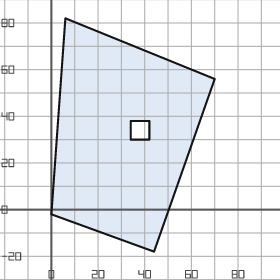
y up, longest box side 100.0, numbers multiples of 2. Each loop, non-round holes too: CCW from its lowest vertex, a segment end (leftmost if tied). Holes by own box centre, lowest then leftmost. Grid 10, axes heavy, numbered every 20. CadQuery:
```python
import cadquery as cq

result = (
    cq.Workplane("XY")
    .moveTo(44.0, -18.0)
    .lineTo(70.0, 56.0)
    .lineTo(6.0, 82.0)
    .lineTo(0.0, -2.0)
    .close()
    .moveTo(34.0, 30.0)
    .lineTo(42.0, 30.0)
    .lineTo(42.0, 38.0)
    .lineTo(34.0, 38.0)
    .close()
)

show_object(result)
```